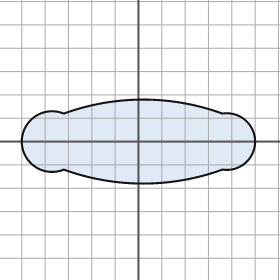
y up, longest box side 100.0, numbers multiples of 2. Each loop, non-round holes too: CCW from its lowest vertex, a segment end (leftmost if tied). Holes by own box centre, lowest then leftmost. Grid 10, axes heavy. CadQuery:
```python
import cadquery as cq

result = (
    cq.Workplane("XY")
    .moveTo(-32.0, -12.0)
    .threePointArc((2.0, -18.0), (36.0, -12.0))
    .threePointArc((50.0, 0.0), (36.0, 12.0))
    .threePointArc((2.0, 18.0), (-32.0, 12.0))
    .threePointArc((-50.0, 0.0), (-32.0, -12.0))
    .close()
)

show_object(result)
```